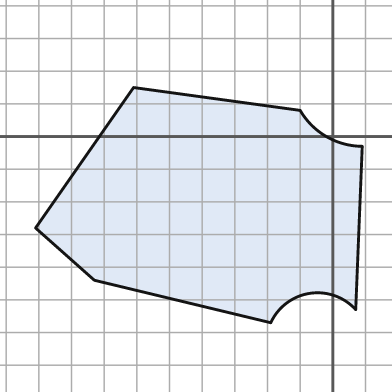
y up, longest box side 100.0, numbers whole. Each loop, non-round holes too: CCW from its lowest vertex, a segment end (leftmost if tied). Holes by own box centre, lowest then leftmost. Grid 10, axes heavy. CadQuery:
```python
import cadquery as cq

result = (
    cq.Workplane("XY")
    .moveTo(-19.0, -57.0)
    .threePointArc((-7.0, -48.0), (7.0, -53.0))
    .lineTo(9.0, -3.0)
    .threePointArc((-2.0, 0.0), (-10.0, 8.0))
    .lineTo(-61.0, 15.0)
    .lineTo(-91.0, -28.0)
    .lineTo(-73.0, -44.0)
    .close()
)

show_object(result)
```